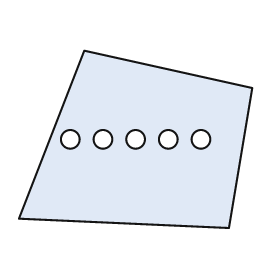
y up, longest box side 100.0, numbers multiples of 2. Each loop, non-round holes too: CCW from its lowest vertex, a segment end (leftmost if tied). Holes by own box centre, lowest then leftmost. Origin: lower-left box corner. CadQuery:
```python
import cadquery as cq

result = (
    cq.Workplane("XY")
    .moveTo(90.0, 0.0)
    .lineTo(100.0, 60.0)
    .lineTo(28.0, 76.0)
    .lineTo(0.0, 4.0)
    .close()
    .moveTo(22.0, 38.0)
    .circle(4.0)
    .moveTo(36.0, 38.0)
    .circle(4.0)
    .moveTo(50.0, 38.0)
    .circle(4.0)
    .moveTo(64.0, 38.0)
    .circle(4.0)
    .moveTo(78.0, 38.0)
    .circle(4.0)
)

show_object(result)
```